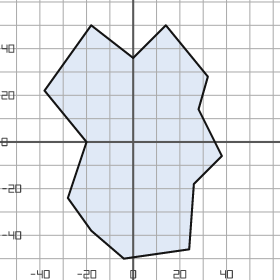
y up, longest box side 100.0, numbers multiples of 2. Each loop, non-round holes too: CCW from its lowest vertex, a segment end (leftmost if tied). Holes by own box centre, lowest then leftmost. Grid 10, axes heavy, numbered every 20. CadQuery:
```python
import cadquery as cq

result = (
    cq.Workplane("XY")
    .moveTo(-4.0, -50.0)
    .lineTo(24.0, -46.0)
    .lineTo(26.0, -18.0)
    .lineTo(38.0, -6.0)
    .lineTo(28.0, 14.0)
    .lineTo(32.0, 28.0)
    .lineTo(14.0, 50.0)
    .lineTo(0.0, 36.0)
    .lineTo(-18.0, 50.0)
    .lineTo(-38.0, 22.0)
    .lineTo(-20.0, 0.0)
    .lineTo(-28.0, -24.0)
    .lineTo(-18.0, -38.0)
    .close()
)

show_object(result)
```